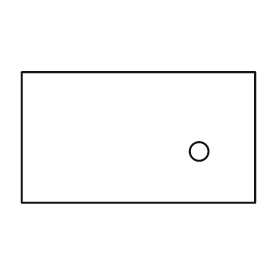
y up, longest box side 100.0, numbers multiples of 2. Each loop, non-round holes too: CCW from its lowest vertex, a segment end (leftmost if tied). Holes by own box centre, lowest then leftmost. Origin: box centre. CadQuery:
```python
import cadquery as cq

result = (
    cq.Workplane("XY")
    .moveTo(-50.0, -28.0)
    .lineTo(50.0, -28.0)
    .lineTo(50.0, 28.0)
    .lineTo(-50.0, 28.0)
    .close()
    .moveTo(26.0, -6.0)
    .circle(4.0)
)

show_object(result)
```